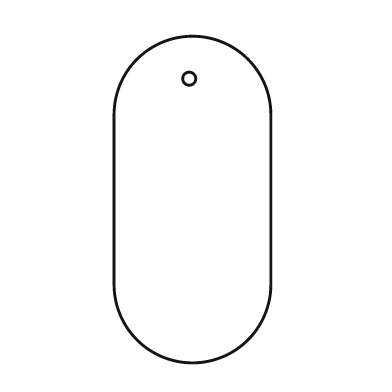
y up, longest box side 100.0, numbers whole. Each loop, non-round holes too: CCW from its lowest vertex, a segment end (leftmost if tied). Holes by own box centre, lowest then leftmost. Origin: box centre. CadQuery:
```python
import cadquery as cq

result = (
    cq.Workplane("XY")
    .moveTo(-24.0, -26.0)
    .threePointArc((0.0, -50.0), (24.0, -26.0))
    .lineTo(24.0, 26.0)
    .threePointArc((0.0, 50.0), (-24.0, 26.0))
    .close()
    .moveTo(-1.0, 37.0)
    .circle(2.0)
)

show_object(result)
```